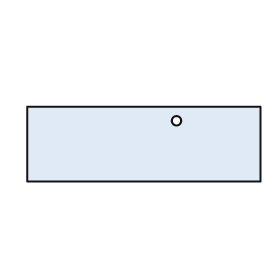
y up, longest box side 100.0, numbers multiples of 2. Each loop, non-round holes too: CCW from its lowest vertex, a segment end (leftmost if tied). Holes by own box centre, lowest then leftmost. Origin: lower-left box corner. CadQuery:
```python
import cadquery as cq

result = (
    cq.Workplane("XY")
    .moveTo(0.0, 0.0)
    .lineTo(100.0, 0.0)
    .lineTo(100.0, 32.0)
    .lineTo(0.0, 32.0)
    .close()
    .moveTo(64.0, 26.0)
    .circle(2.0)
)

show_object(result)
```